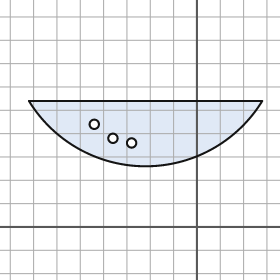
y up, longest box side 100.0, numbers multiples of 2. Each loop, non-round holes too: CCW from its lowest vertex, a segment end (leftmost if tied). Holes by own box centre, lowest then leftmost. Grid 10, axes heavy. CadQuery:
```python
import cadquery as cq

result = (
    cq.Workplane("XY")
    .moveTo(-72.0, 54.0)
    .threePointArc((-22.0, 26.0), (28.0, 54.0))
    .close()
    .moveTo(-28.0, 36.0)
    .circle(2.0)
    .moveTo(-36.0, 38.0)
    .circle(2.0)
    .moveTo(-44.0, 44.0)
    .circle(2.0)
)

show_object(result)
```